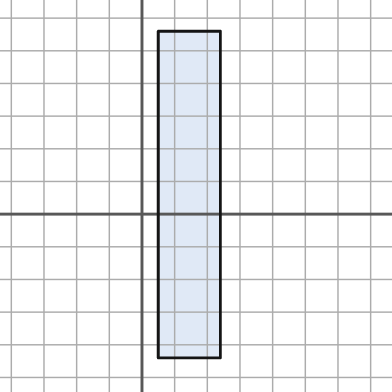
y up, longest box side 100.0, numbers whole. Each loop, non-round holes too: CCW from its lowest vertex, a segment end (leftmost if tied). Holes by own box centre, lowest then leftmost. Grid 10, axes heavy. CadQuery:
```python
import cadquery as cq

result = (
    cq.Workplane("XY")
    .moveTo(5.0, -44.0)
    .lineTo(24.0, -44.0)
    .lineTo(24.0, 56.0)
    .lineTo(5.0, 56.0)
    .close()
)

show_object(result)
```